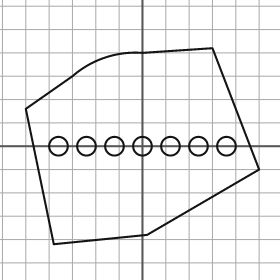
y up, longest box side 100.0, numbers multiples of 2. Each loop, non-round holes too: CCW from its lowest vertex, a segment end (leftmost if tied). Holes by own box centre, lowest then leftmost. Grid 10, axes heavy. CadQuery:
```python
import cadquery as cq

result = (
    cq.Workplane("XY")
    .moveTo(-38.0, -42.0)
    .lineTo(2.0, -38.0)
    .lineTo(50.0, -10.0)
    .lineTo(30.0, 42.0)
    .lineTo(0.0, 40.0)
    .threePointArc((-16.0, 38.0), (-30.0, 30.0))
    .lineTo(-50.0, 16.0)
    .close()
    .moveTo(-36.0, 0.0)
    .circle(4.0)
    .moveTo(-24.0, 0.0)
    .circle(4.0)
    .moveTo(-12.0, 0.0)
    .circle(4.0)
    .moveTo(0.0, 0.0)
    .circle(4.0)
    .moveTo(12.0, 0.0)
    .circle(4.0)
    .moveTo(24.0, 0.0)
    .circle(4.0)
    .moveTo(36.0, 0.0)
    .circle(4.0)
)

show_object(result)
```